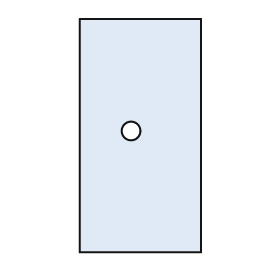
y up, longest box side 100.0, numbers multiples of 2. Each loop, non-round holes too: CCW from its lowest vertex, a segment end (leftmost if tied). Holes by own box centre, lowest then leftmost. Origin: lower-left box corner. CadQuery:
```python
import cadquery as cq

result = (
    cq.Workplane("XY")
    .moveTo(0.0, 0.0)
    .lineTo(52.0, 0.0)
    .lineTo(52.0, 100.0)
    .lineTo(0.0, 100.0)
    .close()
    .moveTo(22.0, 52.0)
    .circle(4.0)
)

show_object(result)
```